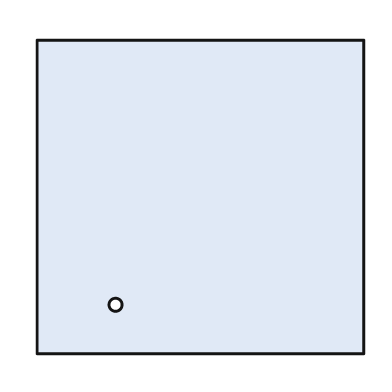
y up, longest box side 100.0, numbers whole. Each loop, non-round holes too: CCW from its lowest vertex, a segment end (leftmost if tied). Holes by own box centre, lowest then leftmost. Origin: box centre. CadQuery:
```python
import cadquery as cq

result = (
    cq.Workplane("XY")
    .moveTo(-50.0, -48.0)
    .lineTo(50.0, -48.0)
    .lineTo(50.0, 48.0)
    .lineTo(-50.0, 48.0)
    .close()
    .moveTo(-26.0, -33.0)
    .circle(2.0)
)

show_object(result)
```